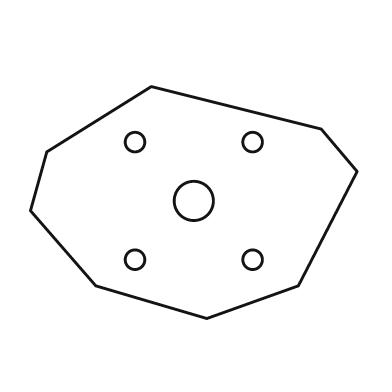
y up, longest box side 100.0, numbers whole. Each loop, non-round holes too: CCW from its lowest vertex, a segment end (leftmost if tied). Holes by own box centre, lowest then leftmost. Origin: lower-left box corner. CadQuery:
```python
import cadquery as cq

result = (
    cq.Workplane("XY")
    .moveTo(54.0, 0.0)
    .lineTo(82.0, 10.0)
    .lineTo(100.0, 45.0)
    .lineTo(89.0, 58.0)
    .lineTo(37.0, 71.0)
    .lineTo(5.0, 51.0)
    .lineTo(0.0, 33.0)
    .lineTo(20.0, 10.0)
    .close()
    .moveTo(32.0, 18.0)
    .circle(3.0)
    .moveTo(68.0, 18.0)
    .circle(3.0)
    .moveTo(50.0, 36.0)
    .circle(6.0)
    .moveTo(32.0, 54.0)
    .circle(3.0)
    .moveTo(68.0, 54.0)
    .circle(3.0)
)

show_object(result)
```